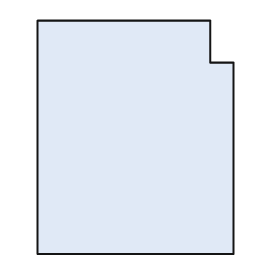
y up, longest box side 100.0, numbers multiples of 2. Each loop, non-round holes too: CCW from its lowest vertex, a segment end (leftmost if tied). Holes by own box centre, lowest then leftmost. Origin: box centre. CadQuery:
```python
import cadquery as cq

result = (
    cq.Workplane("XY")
    .moveTo(-42.0, -50.0)
    .lineTo(42.0, -50.0)
    .lineTo(42.0, 32.0)
    .lineTo(32.0, 32.0)
    .lineTo(32.0, 50.0)
    .lineTo(-42.0, 50.0)
    .close()
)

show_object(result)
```